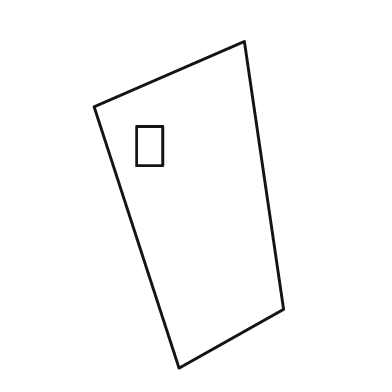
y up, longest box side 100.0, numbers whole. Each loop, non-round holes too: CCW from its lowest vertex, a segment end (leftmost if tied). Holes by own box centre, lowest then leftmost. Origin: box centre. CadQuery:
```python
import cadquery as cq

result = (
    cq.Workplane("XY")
    .moveTo(-3.0, -50.0)
    .lineTo(29.0, -32.0)
    .lineTo(17.0, 50.0)
    .lineTo(-29.0, 30.0)
    .close()
    .moveTo(-16.0, 12.0)
    .lineTo(-8.0, 12.0)
    .lineTo(-8.0, 24.0)
    .lineTo(-16.0, 24.0)
    .close()
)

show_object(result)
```